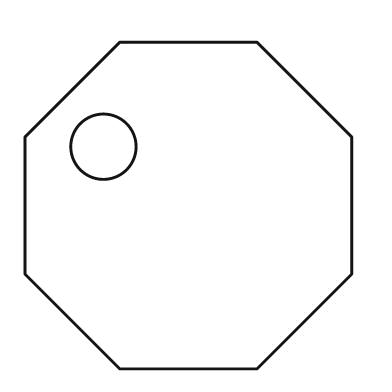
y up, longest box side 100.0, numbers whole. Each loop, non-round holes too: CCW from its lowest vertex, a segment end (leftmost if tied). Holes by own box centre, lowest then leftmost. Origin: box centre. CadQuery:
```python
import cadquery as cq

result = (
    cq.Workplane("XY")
    .moveTo(-21.0, -50.0)
    .lineTo(21.0, -50.0)
    .lineTo(50.0, -21.0)
    .lineTo(50.0, 21.0)
    .lineTo(21.0, 50.0)
    .lineTo(-21.0, 50.0)
    .lineTo(-50.0, 21.0)
    .lineTo(-50.0, -21.0)
    .close()
    .moveTo(-26.0, 18.0)
    .circle(10.0)
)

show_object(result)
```